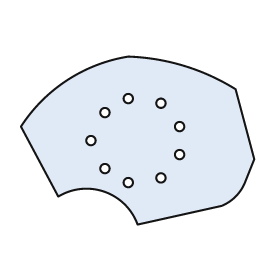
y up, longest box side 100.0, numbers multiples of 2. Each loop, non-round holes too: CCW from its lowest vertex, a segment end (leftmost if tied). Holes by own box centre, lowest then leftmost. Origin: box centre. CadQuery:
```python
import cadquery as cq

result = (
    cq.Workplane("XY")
    .moveTo(0.0, -36.0)
    .lineTo(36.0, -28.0)
    .threePointArc((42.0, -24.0), (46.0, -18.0))
    .lineTo(50.0, -8.0)
    .lineTo(42.0, 22.0)
    .threePointArc((20.0, 32.0), (-4.0, 36.0))
    .threePointArc((-30.0, 26.0), (-50.0, 6.0))
    .lineTo(-34.0, -24.0)
    .threePointArc((-14.0, -22.0), (0.0, -36.0))
    .close()
    .moveTo(-4.0, -18.0)
    .circle(2.0)
    .moveTo(10.0, -16.0)
    .circle(2.0)
    .moveTo(-14.0, -12.0)
    .circle(2.0)
    .moveTo(18.0, -6.0)
    .circle(2.0)
    .moveTo(-20.0, 0.0)
    .circle(2.0)
    .moveTo(18.0, 6.0)
    .circle(2.0)
    .moveTo(-14.0, 12.0)
    .circle(2.0)
    .moveTo(10.0, 16.0)
    .circle(2.0)
    .moveTo(-4.0, 18.0)
    .circle(2.0)
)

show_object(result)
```